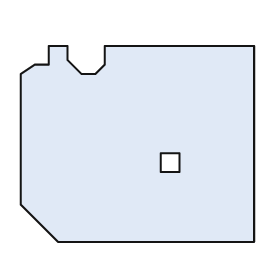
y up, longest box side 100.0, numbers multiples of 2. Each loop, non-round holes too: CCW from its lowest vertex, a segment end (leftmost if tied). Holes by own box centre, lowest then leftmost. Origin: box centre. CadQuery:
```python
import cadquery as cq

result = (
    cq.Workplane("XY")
    .moveTo(-34.0, -42.0)
    .lineTo(50.0, -42.0)
    .lineTo(50.0, 42.0)
    .lineTo(-14.0, 42.0)
    .lineTo(-14.0, 34.0)
    .lineTo(-18.0, 30.0)
    .lineTo(-24.0, 30.0)
    .lineTo(-30.0, 36.0)
    .lineTo(-30.0, 42.0)
    .lineTo(-38.0, 42.0)
    .lineTo(-38.0, 34.0)
    .lineTo(-44.0, 34.0)
    .lineTo(-50.0, 30.0)
    .lineTo(-50.0, -26.0)
    .close()
    .moveTo(10.0, -12.0)
    .lineTo(18.0, -12.0)
    .lineTo(18.0, -4.0)
    .lineTo(10.0, -4.0)
    .close()
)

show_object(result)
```